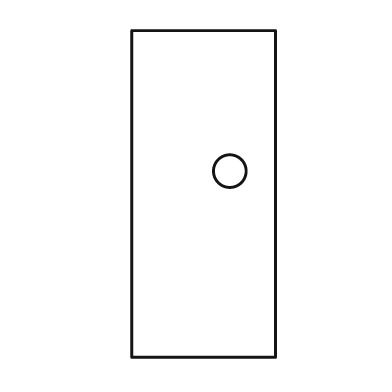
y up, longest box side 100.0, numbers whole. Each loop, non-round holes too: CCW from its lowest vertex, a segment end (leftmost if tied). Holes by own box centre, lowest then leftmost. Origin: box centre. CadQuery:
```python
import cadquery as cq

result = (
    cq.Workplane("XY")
    .moveTo(-22.0, -50.0)
    .lineTo(22.0, -50.0)
    .lineTo(22.0, 50.0)
    .lineTo(-22.0, 50.0)
    .close()
    .moveTo(8.0, 7.0)
    .circle(5.0)
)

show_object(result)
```